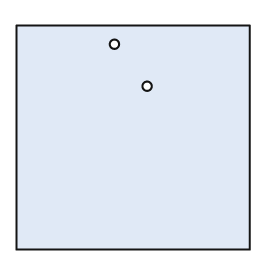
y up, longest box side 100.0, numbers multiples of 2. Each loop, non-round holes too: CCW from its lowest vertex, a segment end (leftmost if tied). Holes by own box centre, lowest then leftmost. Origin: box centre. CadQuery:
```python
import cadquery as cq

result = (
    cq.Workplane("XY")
    .moveTo(-50.0, -48.0)
    .lineTo(50.0, -48.0)
    .lineTo(50.0, 48.0)
    .lineTo(-50.0, 48.0)
    .close()
    .moveTo(6.0, 22.0)
    .circle(2.0)
    .moveTo(-8.0, 40.0)
    .circle(2.0)
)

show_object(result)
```